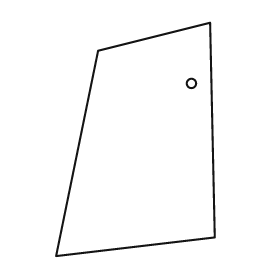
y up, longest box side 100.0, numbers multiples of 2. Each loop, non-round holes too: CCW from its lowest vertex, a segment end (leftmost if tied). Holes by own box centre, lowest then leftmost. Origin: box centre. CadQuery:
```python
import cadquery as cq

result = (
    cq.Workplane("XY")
    .moveTo(-34.0, -50.0)
    .lineTo(34.0, -42.0)
    .lineTo(32.0, 50.0)
    .lineTo(-16.0, 38.0)
    .close()
    .moveTo(24.0, 24.0)
    .circle(2.0)
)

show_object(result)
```